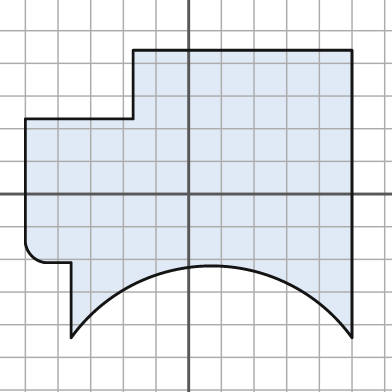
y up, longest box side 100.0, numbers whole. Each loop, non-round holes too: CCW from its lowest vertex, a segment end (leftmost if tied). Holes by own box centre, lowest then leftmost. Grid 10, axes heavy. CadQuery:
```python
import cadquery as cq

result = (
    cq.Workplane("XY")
    .moveTo(-36.0, -44.0)
    .threePointArc((7.0, -22.0), (50.0, -44.0))
    .lineTo(50.0, 44.0)
    .lineTo(-17.0, 44.0)
    .lineTo(-17.0, 23.0)
    .lineTo(-50.0, 23.0)
    .lineTo(-50.0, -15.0)
    .threePointArc((-48.0, -19.0), (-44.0, -21.0))
    .lineTo(-36.0, -21.0)
    .close()
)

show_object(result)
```